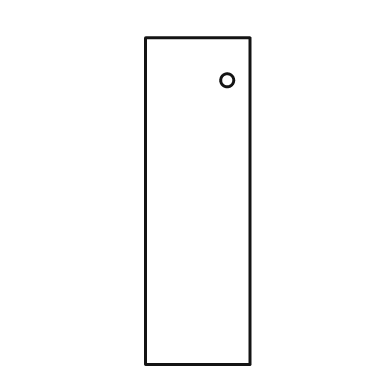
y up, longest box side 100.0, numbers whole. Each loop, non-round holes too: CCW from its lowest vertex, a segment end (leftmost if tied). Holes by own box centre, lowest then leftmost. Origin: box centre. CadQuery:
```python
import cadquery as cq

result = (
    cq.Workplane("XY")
    .moveTo(-16.0, -50.0)
    .lineTo(16.0, -50.0)
    .lineTo(16.0, 50.0)
    .lineTo(-16.0, 50.0)
    .close()
    .moveTo(9.0, 37.0)
    .circle(2.0)
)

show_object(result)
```